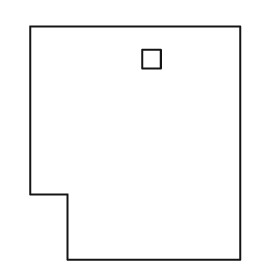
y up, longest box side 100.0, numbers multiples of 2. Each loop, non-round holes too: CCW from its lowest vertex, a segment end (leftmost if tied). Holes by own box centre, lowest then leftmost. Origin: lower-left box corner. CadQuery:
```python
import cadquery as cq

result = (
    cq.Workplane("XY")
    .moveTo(16.0, 0.0)
    .lineTo(90.0, 0.0)
    .lineTo(90.0, 100.0)
    .lineTo(0.0, 100.0)
    .lineTo(0.0, 28.0)
    .lineTo(16.0, 28.0)
    .close()
    .moveTo(48.0, 82.0)
    .lineTo(56.0, 82.0)
    .lineTo(56.0, 90.0)
    .lineTo(48.0, 90.0)
    .close()
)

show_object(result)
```